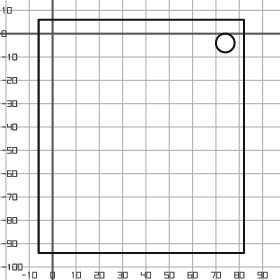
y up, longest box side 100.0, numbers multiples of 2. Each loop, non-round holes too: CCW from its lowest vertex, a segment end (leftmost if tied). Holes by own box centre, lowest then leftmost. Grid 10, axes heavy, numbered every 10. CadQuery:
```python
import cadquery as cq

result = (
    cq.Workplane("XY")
    .moveTo(-6.0, -94.0)
    .lineTo(82.0, -94.0)
    .lineTo(82.0, 6.0)
    .lineTo(-6.0, 6.0)
    .close()
    .moveTo(74.0, -4.0)
    .circle(4.0)
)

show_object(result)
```